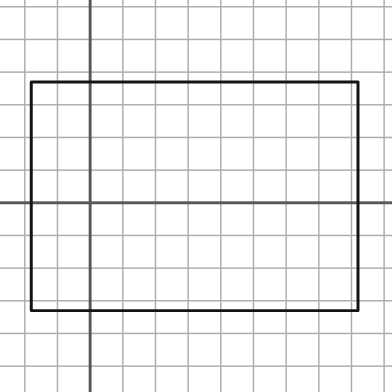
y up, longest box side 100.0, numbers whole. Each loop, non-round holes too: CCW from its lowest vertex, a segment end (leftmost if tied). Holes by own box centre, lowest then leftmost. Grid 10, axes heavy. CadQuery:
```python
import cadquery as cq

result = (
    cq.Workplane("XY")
    .moveTo(-18.0, -33.0)
    .lineTo(82.0, -33.0)
    .lineTo(82.0, 37.0)
    .lineTo(-18.0, 37.0)
    .close()
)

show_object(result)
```